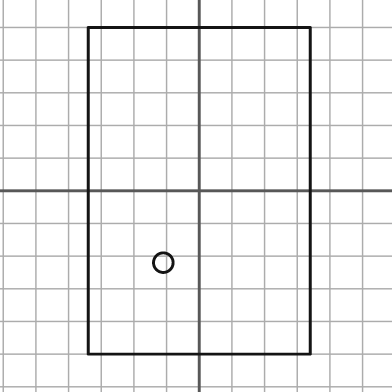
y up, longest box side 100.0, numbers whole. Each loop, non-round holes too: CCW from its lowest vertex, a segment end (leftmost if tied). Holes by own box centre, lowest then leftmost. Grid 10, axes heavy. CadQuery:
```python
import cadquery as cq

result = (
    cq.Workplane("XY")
    .moveTo(-34.0, -50.0)
    .lineTo(34.0, -50.0)
    .lineTo(34.0, 50.0)
    .lineTo(-34.0, 50.0)
    .close()
    .moveTo(-11.0, -22.0)
    .circle(3.0)
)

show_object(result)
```